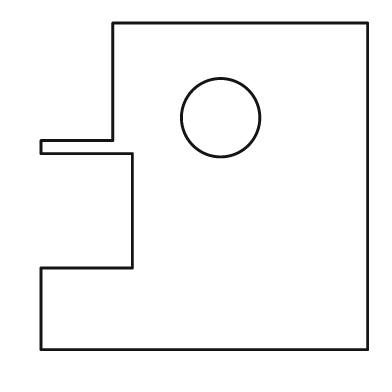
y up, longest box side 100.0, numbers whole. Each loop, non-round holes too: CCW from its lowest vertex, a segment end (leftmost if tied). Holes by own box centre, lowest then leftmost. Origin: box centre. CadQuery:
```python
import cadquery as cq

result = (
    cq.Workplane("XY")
    .moveTo(-50.0, -50.0)
    .lineTo(50.0, -50.0)
    .lineTo(50.0, 50.0)
    .lineTo(-28.0, 50.0)
    .lineTo(-28.0, 14.0)
    .lineTo(-50.0, 14.0)
    .lineTo(-50.0, 10.0)
    .lineTo(-22.0, 10.0)
    .lineTo(-22.0, -25.0)
    .lineTo(-50.0, -25.0)
    .close()
    .moveTo(5.0, 21.0)
    .circle(12.0)
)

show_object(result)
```